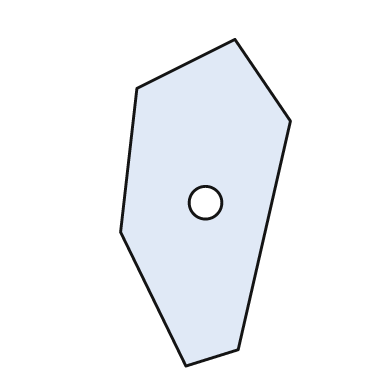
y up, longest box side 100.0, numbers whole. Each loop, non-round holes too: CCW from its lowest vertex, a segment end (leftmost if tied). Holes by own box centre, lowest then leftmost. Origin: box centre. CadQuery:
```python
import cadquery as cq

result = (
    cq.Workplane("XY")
    .moveTo(-6.0, -50.0)
    .lineTo(10.0, -45.0)
    .lineTo(26.0, 25.0)
    .lineTo(9.0, 50.0)
    .lineTo(-21.0, 35.0)
    .lineTo(-26.0, -9.0)
    .close()
    .moveTo(0.0, 0.0)
    .circle(5.0)
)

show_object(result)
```